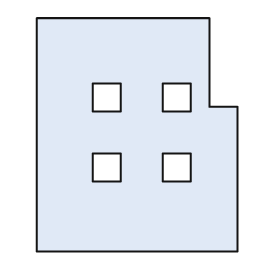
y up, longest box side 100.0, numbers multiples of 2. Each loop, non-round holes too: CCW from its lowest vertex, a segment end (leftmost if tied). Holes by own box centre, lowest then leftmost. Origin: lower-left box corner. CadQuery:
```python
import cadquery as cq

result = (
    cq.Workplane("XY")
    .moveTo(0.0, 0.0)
    .lineTo(86.0, 0.0)
    .lineTo(86.0, 62.0)
    .lineTo(74.0, 62.0)
    .lineTo(74.0, 100.0)
    .lineTo(0.0, 100.0)
    .close()
    .moveTo(24.0, 30.0)
    .lineTo(36.0, 30.0)
    .lineTo(36.0, 42.0)
    .lineTo(24.0, 42.0)
    .close()
    .moveTo(54.0, 30.0)
    .lineTo(66.0, 30.0)
    .lineTo(66.0, 42.0)
    .lineTo(54.0, 42.0)
    .close()
    .moveTo(24.0, 60.0)
    .lineTo(36.0, 60.0)
    .lineTo(36.0, 72.0)
    .lineTo(24.0, 72.0)
    .close()
    .moveTo(54.0, 60.0)
    .lineTo(66.0, 60.0)
    .lineTo(66.0, 72.0)
    .lineTo(54.0, 72.0)
    .close()
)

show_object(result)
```